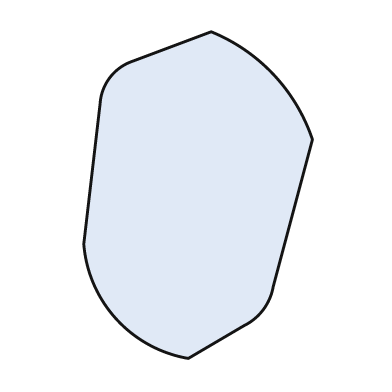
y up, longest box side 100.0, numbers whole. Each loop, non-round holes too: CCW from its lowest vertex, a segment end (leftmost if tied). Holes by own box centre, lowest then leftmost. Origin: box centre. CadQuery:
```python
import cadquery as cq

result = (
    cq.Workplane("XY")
    .moveTo(-3.0, -50.0)
    .lineTo(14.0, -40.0)
    .threePointArc((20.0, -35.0), (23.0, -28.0))
    .lineTo(35.0, 17.0)
    .threePointArc((23.0, 37.0), (4.0, 50.0))
    .lineTo(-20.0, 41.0)
    .threePointArc((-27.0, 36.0), (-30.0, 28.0))
    .lineTo(-35.0, -15.0)
    .threePointArc((-25.0, -38.0), (-3.0, -50.0))
    .close()
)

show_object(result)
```